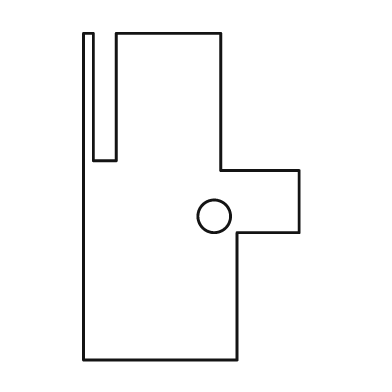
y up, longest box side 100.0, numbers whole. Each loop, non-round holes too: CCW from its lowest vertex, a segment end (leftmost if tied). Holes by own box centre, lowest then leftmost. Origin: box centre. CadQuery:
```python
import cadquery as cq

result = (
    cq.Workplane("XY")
    .moveTo(-33.0, -50.0)
    .lineTo(14.0, -50.0)
    .lineTo(14.0, -11.0)
    .lineTo(33.0, -11.0)
    .lineTo(33.0, 8.0)
    .lineTo(9.0, 8.0)
    .lineTo(9.0, 50.0)
    .lineTo(-23.0, 50.0)
    .lineTo(-23.0, 11.0)
    .lineTo(-30.0, 11.0)
    .lineTo(-30.0, 50.0)
    .lineTo(-33.0, 50.0)
    .close()
    .moveTo(7.0, -6.0)
    .circle(5.0)
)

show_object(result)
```